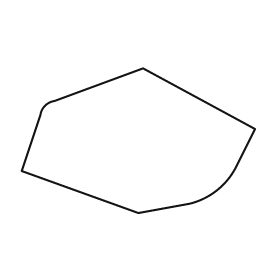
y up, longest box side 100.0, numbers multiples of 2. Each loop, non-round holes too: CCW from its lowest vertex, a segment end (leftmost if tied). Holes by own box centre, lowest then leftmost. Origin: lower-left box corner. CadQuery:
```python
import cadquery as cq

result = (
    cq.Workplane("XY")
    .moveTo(50.0, 0.0)
    .lineTo(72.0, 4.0)
    .threePointArc((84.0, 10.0), (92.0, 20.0))
    .lineTo(100.0, 36.0)
    .lineTo(52.0, 62.0)
    .lineTo(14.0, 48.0)
    .threePointArc((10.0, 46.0), (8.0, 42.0))
    .lineTo(0.0, 18.0)
    .close()
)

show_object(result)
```